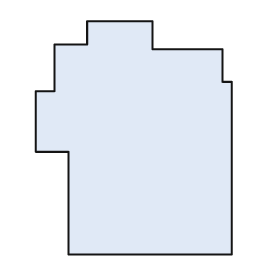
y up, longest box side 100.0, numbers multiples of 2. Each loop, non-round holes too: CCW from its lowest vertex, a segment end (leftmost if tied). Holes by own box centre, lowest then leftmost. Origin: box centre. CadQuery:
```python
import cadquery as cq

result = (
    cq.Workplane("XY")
    .moveTo(-28.0, -50.0)
    .lineTo(42.0, -50.0)
    .lineTo(42.0, 24.0)
    .lineTo(38.0, 24.0)
    .lineTo(38.0, 38.0)
    .lineTo(8.0, 38.0)
    .lineTo(8.0, 50.0)
    .lineTo(-20.0, 50.0)
    .lineTo(-20.0, 40.0)
    .lineTo(-34.0, 40.0)
    .lineTo(-34.0, 20.0)
    .lineTo(-42.0, 20.0)
    .lineTo(-42.0, -6.0)
    .lineTo(-28.0, -6.0)
    .close()
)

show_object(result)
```